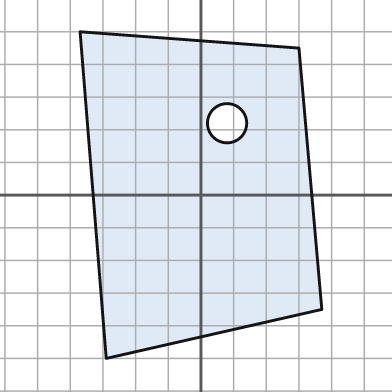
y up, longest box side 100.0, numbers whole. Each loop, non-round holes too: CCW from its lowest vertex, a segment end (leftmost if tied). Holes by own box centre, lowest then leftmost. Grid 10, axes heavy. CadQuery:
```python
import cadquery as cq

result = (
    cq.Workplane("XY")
    .moveTo(-29.0, -50.0)
    .lineTo(37.0, -35.0)
    .lineTo(30.0, 45.0)
    .lineTo(-37.0, 50.0)
    .close()
    .moveTo(8.0, 22.0)
    .circle(6.0)
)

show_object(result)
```